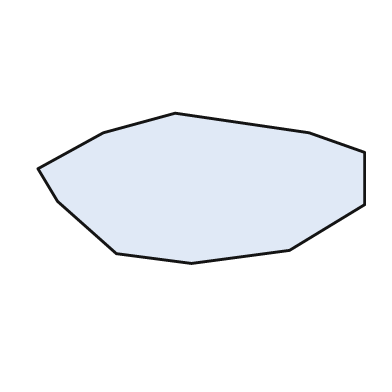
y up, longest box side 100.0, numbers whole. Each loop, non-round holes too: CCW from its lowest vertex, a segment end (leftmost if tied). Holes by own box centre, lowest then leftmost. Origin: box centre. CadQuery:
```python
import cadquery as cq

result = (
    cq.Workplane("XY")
    .moveTo(-3.0, -23.0)
    .lineTo(27.0, -19.0)
    .lineTo(50.0, -5.0)
    .lineTo(50.0, 11.0)
    .lineTo(33.0, 17.0)
    .lineTo(-8.0, 23.0)
    .lineTo(-30.0, 17.0)
    .lineTo(-50.0, 6.0)
    .lineTo(-44.0, -4.0)
    .lineTo(-26.0, -20.0)
    .close()
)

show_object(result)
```